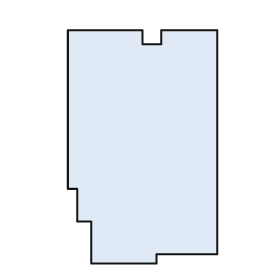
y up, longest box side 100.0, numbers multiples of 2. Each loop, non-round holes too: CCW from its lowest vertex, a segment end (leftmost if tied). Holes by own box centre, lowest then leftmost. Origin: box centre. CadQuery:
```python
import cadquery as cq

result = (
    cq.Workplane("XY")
    .moveTo(-22.0, -50.0)
    .lineTo(6.0, -50.0)
    .lineTo(6.0, -46.0)
    .lineTo(32.0, -46.0)
    .lineTo(32.0, 50.0)
    .lineTo(8.0, 50.0)
    .lineTo(8.0, 44.0)
    .lineTo(0.0, 44.0)
    .lineTo(0.0, 50.0)
    .lineTo(-32.0, 50.0)
    .lineTo(-32.0, -18.0)
    .lineTo(-28.0, -18.0)
    .lineTo(-28.0, -32.0)
    .lineTo(-22.0, -32.0)
    .close()
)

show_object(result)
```